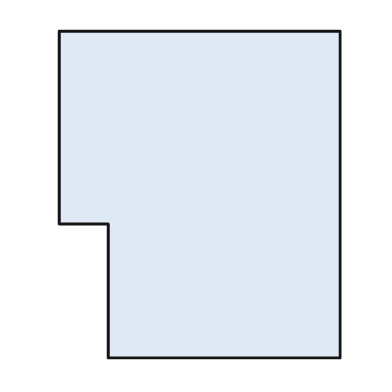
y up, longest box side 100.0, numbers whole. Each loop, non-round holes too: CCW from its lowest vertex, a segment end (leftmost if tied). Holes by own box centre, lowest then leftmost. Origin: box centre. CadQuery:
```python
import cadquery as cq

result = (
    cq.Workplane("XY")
    .moveTo(-28.0, -50.0)
    .lineTo(43.0, -50.0)
    .lineTo(43.0, 50.0)
    .lineTo(-43.0, 50.0)
    .lineTo(-43.0, -9.0)
    .lineTo(-28.0, -9.0)
    .close()
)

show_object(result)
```